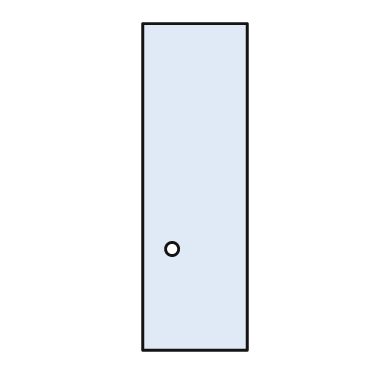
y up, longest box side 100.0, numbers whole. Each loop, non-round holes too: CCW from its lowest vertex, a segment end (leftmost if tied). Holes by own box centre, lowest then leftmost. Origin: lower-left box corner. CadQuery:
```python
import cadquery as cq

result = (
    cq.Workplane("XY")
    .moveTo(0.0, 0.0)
    .lineTo(32.0, 0.0)
    .lineTo(32.0, 100.0)
    .lineTo(0.0, 100.0)
    .close()
    .moveTo(9.0, 31.0)
    .circle(2.0)
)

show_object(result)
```